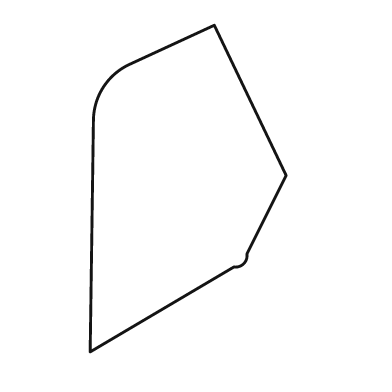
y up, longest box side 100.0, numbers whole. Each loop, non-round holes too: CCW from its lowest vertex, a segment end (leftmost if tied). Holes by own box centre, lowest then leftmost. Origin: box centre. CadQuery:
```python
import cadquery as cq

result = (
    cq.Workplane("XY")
    .moveTo(-30.0, -50.0)
    .lineTo(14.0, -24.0)
    .threePointArc((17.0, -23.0), (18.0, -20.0))
    .lineTo(30.0, 4.0)
    .lineTo(8.0, 50.0)
    .lineTo(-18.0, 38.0)
    .threePointArc((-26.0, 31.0), (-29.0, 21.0))
    .close()
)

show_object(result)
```